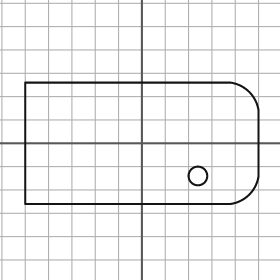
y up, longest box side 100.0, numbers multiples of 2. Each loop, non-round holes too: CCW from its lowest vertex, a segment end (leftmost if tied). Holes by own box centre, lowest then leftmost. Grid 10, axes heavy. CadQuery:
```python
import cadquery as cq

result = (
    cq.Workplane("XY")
    .moveTo(-50.0, -26.0)
    .lineTo(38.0, -26.0)
    .threePointArc((46.0, -22.0), (50.0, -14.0))
    .lineTo(50.0, 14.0)
    .threePointArc((46.0, 22.0), (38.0, 26.0))
    .lineTo(-50.0, 26.0)
    .close()
    .moveTo(24.0, -14.0)
    .circle(4.0)
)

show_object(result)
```